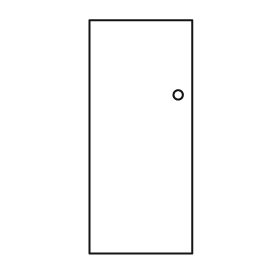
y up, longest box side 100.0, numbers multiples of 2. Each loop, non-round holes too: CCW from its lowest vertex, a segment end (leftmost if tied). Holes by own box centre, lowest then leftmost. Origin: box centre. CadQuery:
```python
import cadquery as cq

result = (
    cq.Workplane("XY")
    .moveTo(-22.0, -50.0)
    .lineTo(22.0, -50.0)
    .lineTo(22.0, 50.0)
    .lineTo(-22.0, 50.0)
    .close()
    .moveTo(16.0, 18.0)
    .circle(2.0)
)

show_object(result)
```